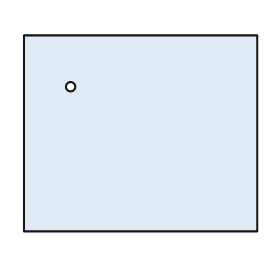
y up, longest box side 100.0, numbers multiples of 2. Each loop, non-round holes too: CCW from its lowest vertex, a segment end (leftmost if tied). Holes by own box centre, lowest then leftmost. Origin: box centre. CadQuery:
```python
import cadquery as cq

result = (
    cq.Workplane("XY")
    .moveTo(-50.0, -42.0)
    .lineTo(50.0, -42.0)
    .lineTo(50.0, 42.0)
    .lineTo(-50.0, 42.0)
    .close()
    .moveTo(-30.0, 20.0)
    .circle(2.0)
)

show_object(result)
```